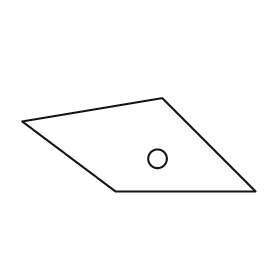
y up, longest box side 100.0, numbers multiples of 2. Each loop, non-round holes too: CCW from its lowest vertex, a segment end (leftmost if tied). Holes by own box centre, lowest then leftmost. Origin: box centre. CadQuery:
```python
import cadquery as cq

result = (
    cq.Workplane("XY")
    .moveTo(-10.0, -20.0)
    .lineTo(50.0, -20.0)
    .lineTo(10.0, 20.0)
    .lineTo(-50.0, 10.0)
    .close()
    .moveTo(8.0, -6.0)
    .circle(4.0)
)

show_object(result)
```